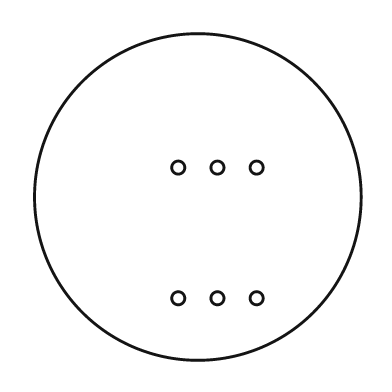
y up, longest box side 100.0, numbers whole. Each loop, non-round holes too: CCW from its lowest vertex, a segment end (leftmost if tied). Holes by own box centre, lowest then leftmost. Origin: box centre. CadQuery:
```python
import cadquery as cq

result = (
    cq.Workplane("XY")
    .moveTo(0.0, 0.0)
    .circle(50.0)
    .moveTo(-6.0, -31.0)
    .circle(2.0)
    .moveTo(6.0, -31.0)
    .circle(2.0)
    .moveTo(18.0, -31.0)
    .circle(2.0)
    .moveTo(-6.0, 9.0)
    .circle(2.0)
    .moveTo(6.0, 9.0)
    .circle(2.0)
    .moveTo(18.0, 9.0)
    .circle(2.0)
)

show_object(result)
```